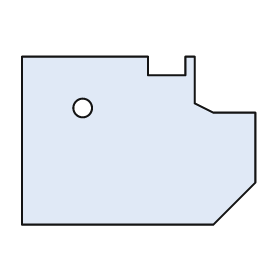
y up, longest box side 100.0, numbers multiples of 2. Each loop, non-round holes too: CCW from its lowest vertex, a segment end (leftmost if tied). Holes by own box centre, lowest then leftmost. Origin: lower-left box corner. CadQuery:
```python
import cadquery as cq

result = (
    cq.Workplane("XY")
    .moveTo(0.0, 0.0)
    .lineTo(82.0, 0.0)
    .lineTo(100.0, 18.0)
    .lineTo(100.0, 48.0)
    .lineTo(82.0, 48.0)
    .lineTo(74.0, 52.0)
    .lineTo(74.0, 72.0)
    .lineTo(70.0, 72.0)
    .lineTo(70.0, 64.0)
    .lineTo(54.0, 64.0)
    .lineTo(54.0, 72.0)
    .lineTo(0.0, 72.0)
    .close()
    .moveTo(26.0, 50.0)
    .circle(4.0)
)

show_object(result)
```